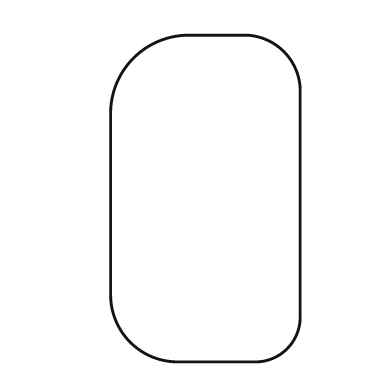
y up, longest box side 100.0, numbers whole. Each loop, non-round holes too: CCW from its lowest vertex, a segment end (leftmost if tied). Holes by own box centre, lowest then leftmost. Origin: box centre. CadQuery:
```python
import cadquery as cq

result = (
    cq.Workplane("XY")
    .moveTo(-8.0, -50.0)
    .lineTo(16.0, -50.0)
    .threePointArc((25.0, -46.0), (29.0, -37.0))
    .lineTo(29.0, 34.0)
    .threePointArc((24.0, 45.0), (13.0, 50.0))
    .lineTo(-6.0, 50.0)
    .threePointArc((-22.0, 43.0), (-29.0, 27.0))
    .lineTo(-29.0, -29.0)
    .threePointArc((-23.0, -44.0), (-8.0, -50.0))
    .close()
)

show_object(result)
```